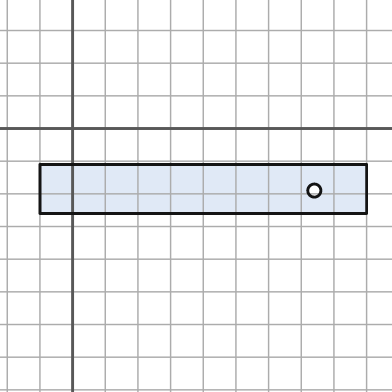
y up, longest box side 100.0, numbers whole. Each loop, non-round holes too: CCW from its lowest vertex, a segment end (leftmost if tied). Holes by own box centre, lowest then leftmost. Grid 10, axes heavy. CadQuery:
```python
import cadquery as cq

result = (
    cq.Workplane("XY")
    .moveTo(-10.0, -26.0)
    .lineTo(90.0, -26.0)
    .lineTo(90.0, -11.0)
    .lineTo(-10.0, -11.0)
    .close()
    .moveTo(74.0, -19.0)
    .circle(2.0)
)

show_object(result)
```